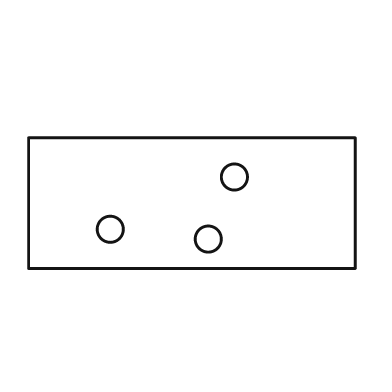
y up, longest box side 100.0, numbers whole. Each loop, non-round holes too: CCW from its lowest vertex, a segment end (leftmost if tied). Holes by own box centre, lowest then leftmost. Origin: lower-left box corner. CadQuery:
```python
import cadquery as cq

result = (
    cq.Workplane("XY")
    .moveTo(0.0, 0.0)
    .lineTo(100.0, 0.0)
    .lineTo(100.0, 40.0)
    .lineTo(0.0, 40.0)
    .close()
    .moveTo(55.0, 9.0)
    .circle(4.0)
    .moveTo(25.0, 12.0)
    .circle(4.0)
    .moveTo(63.0, 28.0)
    .circle(4.0)
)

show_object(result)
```